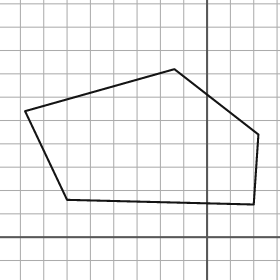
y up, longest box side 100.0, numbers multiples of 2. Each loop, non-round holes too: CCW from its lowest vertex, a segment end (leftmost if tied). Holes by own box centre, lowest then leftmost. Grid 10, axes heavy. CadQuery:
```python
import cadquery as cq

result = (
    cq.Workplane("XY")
    .moveTo(20.0, 14.0)
    .lineTo(22.0, 44.0)
    .lineTo(-14.0, 72.0)
    .lineTo(-78.0, 54.0)
    .lineTo(-60.0, 16.0)
    .close()
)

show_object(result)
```